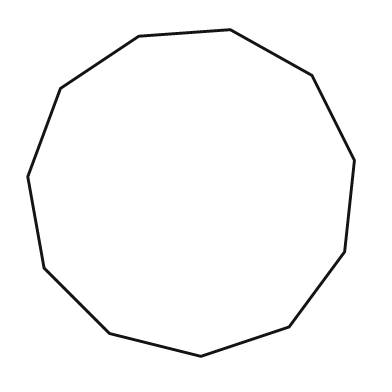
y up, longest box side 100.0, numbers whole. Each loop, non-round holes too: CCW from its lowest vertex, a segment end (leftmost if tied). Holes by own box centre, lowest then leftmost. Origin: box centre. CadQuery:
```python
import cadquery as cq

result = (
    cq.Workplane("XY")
    .moveTo(3.0, -50.0)
    .lineTo(30.0, -41.0)
    .lineTo(47.0, -18.0)
    .lineTo(50.0, 10.0)
    .lineTo(37.0, 36.0)
    .lineTo(12.0, 50.0)
    .lineTo(-16.0, 48.0)
    .lineTo(-40.0, 32.0)
    .lineTo(-50.0, 5.0)
    .lineTo(-45.0, -23.0)
    .lineTo(-25.0, -43.0)
    .close()
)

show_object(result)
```